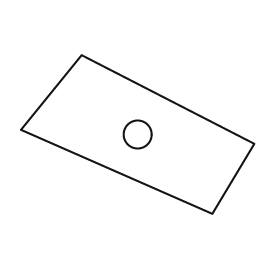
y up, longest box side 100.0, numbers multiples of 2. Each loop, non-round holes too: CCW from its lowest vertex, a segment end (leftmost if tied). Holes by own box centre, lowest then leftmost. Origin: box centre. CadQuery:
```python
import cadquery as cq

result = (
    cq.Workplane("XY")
    .moveTo(32.0, -34.0)
    .lineTo(50.0, -4.0)
    .lineTo(-24.0, 34.0)
    .lineTo(-50.0, 2.0)
    .close()
    .moveTo(0.0, 0.0)
    .circle(6.0)
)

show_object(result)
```